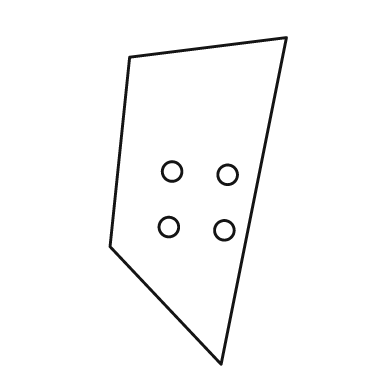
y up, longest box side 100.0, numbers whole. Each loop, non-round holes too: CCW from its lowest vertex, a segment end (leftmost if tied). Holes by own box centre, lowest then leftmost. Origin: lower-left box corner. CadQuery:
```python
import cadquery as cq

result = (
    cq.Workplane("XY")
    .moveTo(34.0, 0.0)
    .lineTo(54.0, 100.0)
    .lineTo(6.0, 94.0)
    .lineTo(0.0, 36.0)
    .close()
    .moveTo(35.0, 41.0)
    .circle(3.0)
    .moveTo(18.0, 42.0)
    .circle(3.0)
    .moveTo(36.0, 58.0)
    .circle(3.0)
    .moveTo(19.0, 59.0)
    .circle(3.0)
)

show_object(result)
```